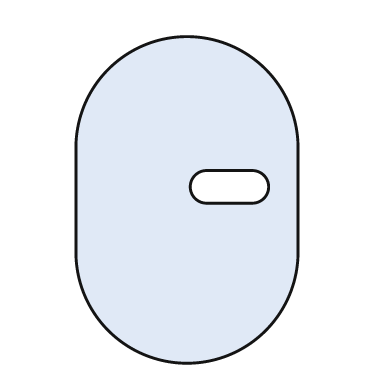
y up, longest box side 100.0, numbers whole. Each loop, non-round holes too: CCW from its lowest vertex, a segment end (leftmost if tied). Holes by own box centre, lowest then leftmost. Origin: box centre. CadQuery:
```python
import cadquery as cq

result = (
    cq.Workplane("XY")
    .moveTo(-34.0, -16.0)
    .threePointArc((0.0, -50.0), (34.0, -16.0))
    .lineTo(34.0, 16.0)
    .threePointArc((0.0, 50.0), (-34.0, 16.0))
    .close()
    .moveTo(6.0, -1.0)
    .lineTo(20.0, -1.0)
    .threePointArc((25.0, 4.0), (20.0, 9.0))
    .lineTo(6.0, 9.0)
    .threePointArc((1.0, 4.0), (6.0, -1.0))
    .close()
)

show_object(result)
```